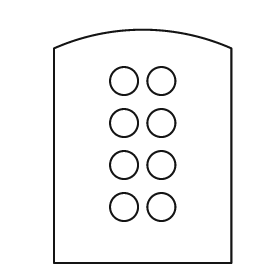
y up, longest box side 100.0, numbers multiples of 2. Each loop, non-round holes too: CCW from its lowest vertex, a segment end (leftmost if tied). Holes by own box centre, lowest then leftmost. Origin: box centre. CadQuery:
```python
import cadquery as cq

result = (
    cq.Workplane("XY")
    .moveTo(-38.0, -50.0)
    .lineTo(38.0, -50.0)
    .lineTo(38.0, 42.0)
    .threePointArc((0.0, 50.0), (-38.0, 42.0))
    .close()
    .moveTo(-8.0, -26.0)
    .circle(6.0)
    .moveTo(8.0, -26.0)
    .circle(6.0)
    .moveTo(-8.0, -8.0)
    .circle(6.0)
    .moveTo(8.0, -8.0)
    .circle(6.0)
    .moveTo(-8.0, 10.0)
    .circle(6.0)
    .moveTo(8.0, 10.0)
    .circle(6.0)
    .moveTo(-8.0, 28.0)
    .circle(6.0)
    .moveTo(8.0, 28.0)
    .circle(6.0)
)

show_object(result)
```